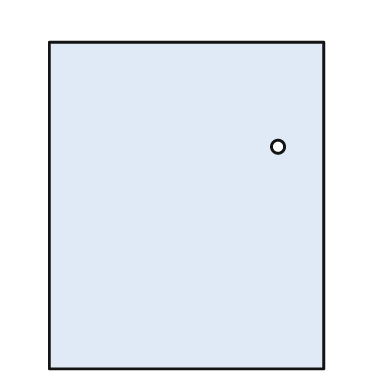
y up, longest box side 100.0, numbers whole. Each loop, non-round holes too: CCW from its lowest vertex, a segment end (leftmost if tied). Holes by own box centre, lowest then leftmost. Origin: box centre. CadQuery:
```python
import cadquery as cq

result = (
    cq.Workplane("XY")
    .moveTo(-42.0, -50.0)
    .lineTo(42.0, -50.0)
    .lineTo(42.0, 50.0)
    .lineTo(-42.0, 50.0)
    .close()
    .moveTo(28.0, 18.0)
    .circle(2.0)
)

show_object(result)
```